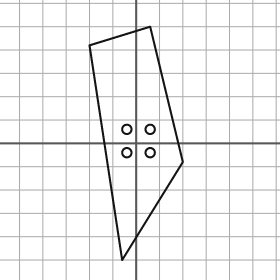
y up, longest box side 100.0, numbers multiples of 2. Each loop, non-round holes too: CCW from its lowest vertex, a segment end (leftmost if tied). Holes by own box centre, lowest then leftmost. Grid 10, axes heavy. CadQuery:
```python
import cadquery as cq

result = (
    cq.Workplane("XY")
    .moveTo(-6.0, -50.0)
    .lineTo(20.0, -8.0)
    .lineTo(6.0, 50.0)
    .lineTo(-20.0, 42.0)
    .close()
    .moveTo(-4.0, -4.0)
    .circle(2.0)
    .moveTo(6.0, -4.0)
    .circle(2.0)
    .moveTo(-4.0, 6.0)
    .circle(2.0)
    .moveTo(6.0, 6.0)
    .circle(2.0)
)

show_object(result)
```